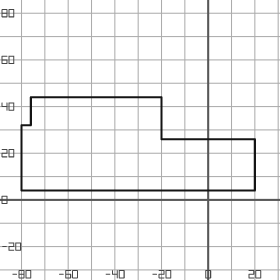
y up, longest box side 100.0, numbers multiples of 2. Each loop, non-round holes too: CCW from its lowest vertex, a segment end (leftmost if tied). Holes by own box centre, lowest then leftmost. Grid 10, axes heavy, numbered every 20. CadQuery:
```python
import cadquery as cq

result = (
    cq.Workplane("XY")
    .moveTo(-80.0, 4.0)
    .lineTo(20.0, 4.0)
    .lineTo(20.0, 26.0)
    .lineTo(-20.0, 26.0)
    .lineTo(-20.0, 44.0)
    .lineTo(-76.0, 44.0)
    .lineTo(-76.0, 32.0)
    .lineTo(-80.0, 32.0)
    .close()
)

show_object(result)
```